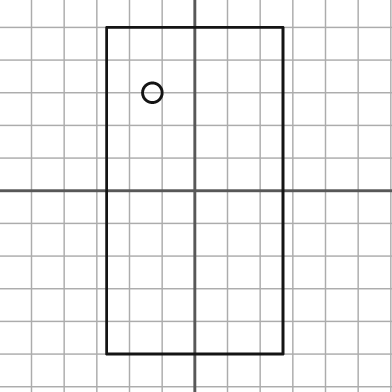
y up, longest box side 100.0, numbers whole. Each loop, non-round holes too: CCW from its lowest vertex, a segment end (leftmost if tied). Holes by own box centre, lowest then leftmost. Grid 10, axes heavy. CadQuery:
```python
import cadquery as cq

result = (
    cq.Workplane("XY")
    .moveTo(-27.0, -50.0)
    .lineTo(27.0, -50.0)
    .lineTo(27.0, 50.0)
    .lineTo(-27.0, 50.0)
    .close()
    .moveTo(-13.0, 30.0)
    .circle(3.0)
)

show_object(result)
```